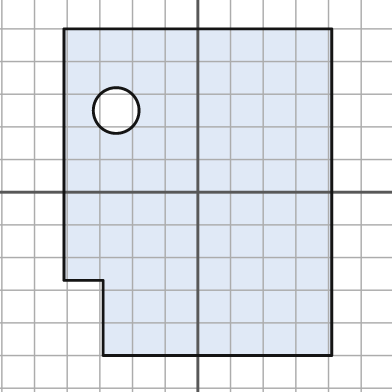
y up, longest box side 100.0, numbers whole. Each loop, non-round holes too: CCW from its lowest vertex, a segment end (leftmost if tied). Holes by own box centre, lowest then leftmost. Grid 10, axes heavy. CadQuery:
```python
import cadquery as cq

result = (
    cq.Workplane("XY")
    .moveTo(-29.0, -50.0)
    .lineTo(41.0, -50.0)
    .lineTo(41.0, 50.0)
    .lineTo(-41.0, 50.0)
    .lineTo(-41.0, -27.0)
    .lineTo(-29.0, -27.0)
    .close()
    .moveTo(-25.0, 25.0)
    .circle(7.0)
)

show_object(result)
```